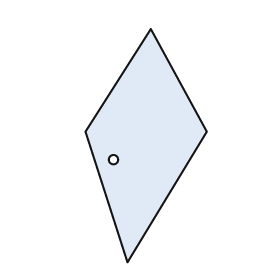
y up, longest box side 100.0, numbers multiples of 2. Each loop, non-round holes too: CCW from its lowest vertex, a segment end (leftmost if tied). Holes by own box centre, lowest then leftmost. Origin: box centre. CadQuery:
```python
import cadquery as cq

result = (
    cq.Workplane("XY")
    .moveTo(-8.0, -50.0)
    .lineTo(26.0, 6.0)
    .lineTo(2.0, 50.0)
    .lineTo(-26.0, 6.0)
    .close()
    .moveTo(-14.0, -6.0)
    .circle(2.0)
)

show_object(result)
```